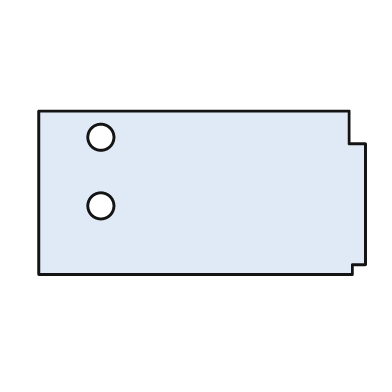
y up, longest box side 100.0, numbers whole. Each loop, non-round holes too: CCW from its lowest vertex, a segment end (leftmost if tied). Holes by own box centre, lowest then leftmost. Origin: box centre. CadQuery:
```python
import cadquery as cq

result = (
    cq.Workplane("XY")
    .moveTo(-50.0, -25.0)
    .lineTo(46.0, -25.0)
    .lineTo(46.0, -22.0)
    .lineTo(50.0, -22.0)
    .lineTo(50.0, 15.0)
    .lineTo(45.0, 15.0)
    .lineTo(45.0, 25.0)
    .lineTo(-50.0, 25.0)
    .close()
    .moveTo(-31.0, -4.0)
    .circle(4.0)
    .moveTo(-31.0, 17.0)
    .circle(4.0)
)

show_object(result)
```